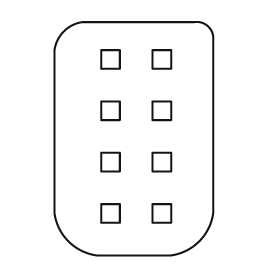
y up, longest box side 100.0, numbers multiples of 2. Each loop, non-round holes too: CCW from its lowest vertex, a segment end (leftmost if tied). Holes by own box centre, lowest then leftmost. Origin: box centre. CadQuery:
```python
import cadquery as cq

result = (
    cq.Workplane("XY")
    .moveTo(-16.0, -50.0)
    .lineTo(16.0, -50.0)
    .threePointArc((28.0, -44.0), (34.0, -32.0))
    .lineTo(34.0, 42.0)
    .threePointArc((32.0, 48.0), (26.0, 50.0))
    .lineTo(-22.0, 50.0)
    .threePointArc((-30.0, 46.0), (-34.0, 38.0))
    .lineTo(-34.0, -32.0)
    .threePointArc((-28.0, -44.0), (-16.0, -50.0))
    .close()
    .moveTo(-14.0, -36.0)
    .lineTo(-6.0, -36.0)
    .lineTo(-6.0, -28.0)
    .lineTo(-14.0, -28.0)
    .close()
    .moveTo(8.0, -36.0)
    .lineTo(16.0, -36.0)
    .lineTo(16.0, -28.0)
    .lineTo(8.0, -28.0)
    .close()
    .moveTo(-14.0, -14.0)
    .lineTo(-6.0, -14.0)
    .lineTo(-6.0, -6.0)
    .lineTo(-14.0, -6.0)
    .close()
    .moveTo(8.0, -14.0)
    .lineTo(16.0, -14.0)
    .lineTo(16.0, -6.0)
    .lineTo(8.0, -6.0)
    .close()
    .moveTo(-14.0, 8.0)
    .lineTo(-6.0, 8.0)
    .lineTo(-6.0, 16.0)
    .lineTo(-14.0, 16.0)
    .close()
    .moveTo(8.0, 8.0)
    .lineTo(16.0, 8.0)
    .lineTo(16.0, 16.0)
    .lineTo(8.0, 16.0)
    .close()
    .moveTo(-14.0, 30.0)
    .lineTo(-6.0, 30.0)
    .lineTo(-6.0, 38.0)
    .lineTo(-14.0, 38.0)
    .close()
    .moveTo(8.0, 30.0)
    .lineTo(16.0, 30.0)
    .lineTo(16.0, 38.0)
    .lineTo(8.0, 38.0)
    .close()
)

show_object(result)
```